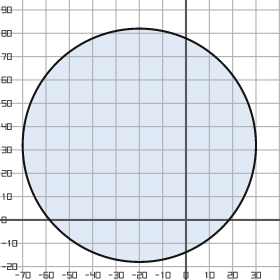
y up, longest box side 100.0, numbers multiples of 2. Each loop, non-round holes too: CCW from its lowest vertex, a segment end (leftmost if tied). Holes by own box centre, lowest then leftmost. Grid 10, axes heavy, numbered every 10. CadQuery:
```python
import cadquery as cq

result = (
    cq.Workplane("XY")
    .moveTo(-20.0, 32.0)
    .circle(50.0)
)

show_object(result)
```